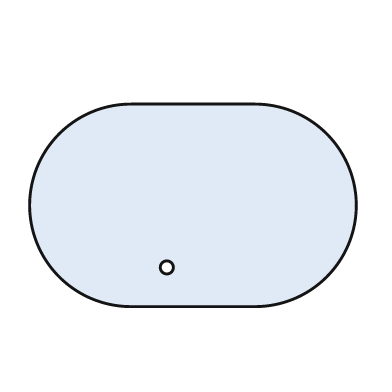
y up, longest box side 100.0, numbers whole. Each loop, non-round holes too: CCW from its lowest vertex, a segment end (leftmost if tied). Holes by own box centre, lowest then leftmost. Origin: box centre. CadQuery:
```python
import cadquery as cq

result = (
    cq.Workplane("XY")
    .moveTo(-19.0, -31.0)
    .lineTo(19.0, -31.0)
    .threePointArc((50.0, 0.0), (19.0, 31.0))
    .lineTo(-19.0, 31.0)
    .threePointArc((-50.0, 0.0), (-19.0, -31.0))
    .close()
    .moveTo(-8.0, -19.0)
    .circle(2.0)
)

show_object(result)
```